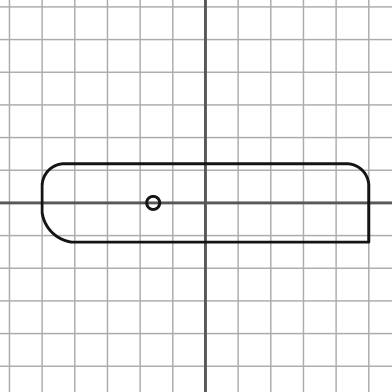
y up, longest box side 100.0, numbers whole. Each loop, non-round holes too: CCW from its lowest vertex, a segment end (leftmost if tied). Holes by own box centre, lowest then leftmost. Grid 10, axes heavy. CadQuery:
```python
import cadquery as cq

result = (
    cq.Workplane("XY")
    .moveTo(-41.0, -12.0)
    .lineTo(50.0, -12.0)
    .lineTo(50.0, 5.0)
    .threePointArc((48.0, 10.0), (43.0, 12.0))
    .lineTo(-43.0, 12.0)
    .threePointArc((-48.0, 10.0), (-50.0, 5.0))
    .lineTo(-50.0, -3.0)
    .threePointArc((-47.0, -9.0), (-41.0, -12.0))
    .close()
    .moveTo(-16.0, 0.0)
    .circle(2.0)
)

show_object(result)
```